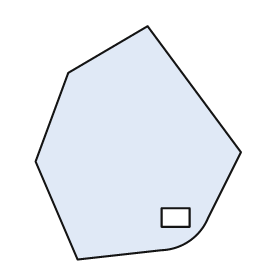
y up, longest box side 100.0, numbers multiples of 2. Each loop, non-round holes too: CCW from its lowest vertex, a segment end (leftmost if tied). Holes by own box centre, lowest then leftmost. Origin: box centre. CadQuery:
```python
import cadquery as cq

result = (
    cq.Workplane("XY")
    .moveTo(-26.0, -50.0)
    .lineTo(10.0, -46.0)
    .threePointArc((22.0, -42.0), (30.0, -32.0))
    .lineTo(44.0, -4.0)
    .lineTo(4.0, 50.0)
    .lineTo(-30.0, 30.0)
    .lineTo(-44.0, -8.0)
    .close()
    .moveTo(10.0, -36.0)
    .lineTo(22.0, -36.0)
    .lineTo(22.0, -28.0)
    .lineTo(10.0, -28.0)
    .close()
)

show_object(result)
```